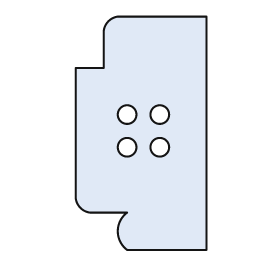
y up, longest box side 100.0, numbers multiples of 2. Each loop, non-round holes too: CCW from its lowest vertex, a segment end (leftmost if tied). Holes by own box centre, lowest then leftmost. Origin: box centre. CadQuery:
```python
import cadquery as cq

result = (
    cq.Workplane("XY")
    .moveTo(-6.0, -50.0)
    .lineTo(28.0, -50.0)
    .lineTo(28.0, 50.0)
    .lineTo(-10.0, 50.0)
    .threePointArc((-14.0, 48.0), (-16.0, 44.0))
    .lineTo(-16.0, 28.0)
    .lineTo(-28.0, 28.0)
    .lineTo(-28.0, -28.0)
    .threePointArc((-26.0, -32.0), (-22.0, -34.0))
    .lineTo(-6.0, -34.0)
    .threePointArc((-10.0, -42.0), (-6.0, -50.0))
    .close()
    .moveTo(-6.0, -6.0)
    .circle(4.0)
    .moveTo(8.0, -6.0)
    .circle(4.0)
    .moveTo(-6.0, 8.0)
    .circle(4.0)
    .moveTo(8.0, 8.0)
    .circle(4.0)
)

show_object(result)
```